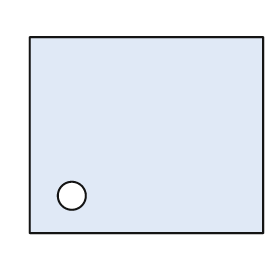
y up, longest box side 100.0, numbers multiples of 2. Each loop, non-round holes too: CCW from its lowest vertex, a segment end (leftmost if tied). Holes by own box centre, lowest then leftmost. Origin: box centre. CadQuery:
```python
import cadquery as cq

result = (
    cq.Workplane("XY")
    .moveTo(-50.0, -42.0)
    .lineTo(50.0, -42.0)
    .lineTo(50.0, 42.0)
    .lineTo(-50.0, 42.0)
    .close()
    .moveTo(-32.0, -26.0)
    .circle(6.0)
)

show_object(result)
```